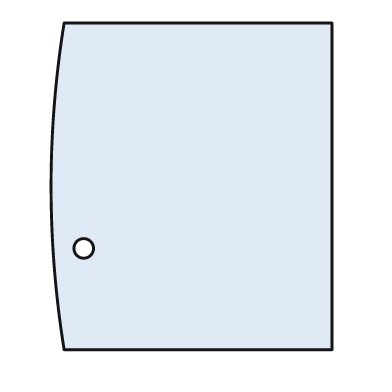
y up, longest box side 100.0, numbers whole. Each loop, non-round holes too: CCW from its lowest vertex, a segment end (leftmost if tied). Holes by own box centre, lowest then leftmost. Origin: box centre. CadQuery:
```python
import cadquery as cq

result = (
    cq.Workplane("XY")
    .moveTo(-39.0, -50.0)
    .lineTo(43.0, -50.0)
    .lineTo(43.0, 50.0)
    .lineTo(-39.0, 50.0)
    .threePointArc((-43.0, 0.0), (-39.0, -50.0))
    .close()
    .moveTo(-33.0, -19.0)
    .circle(3.0)
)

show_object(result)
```